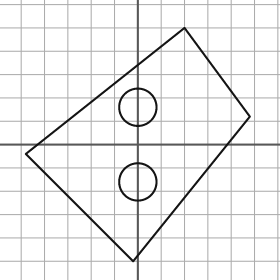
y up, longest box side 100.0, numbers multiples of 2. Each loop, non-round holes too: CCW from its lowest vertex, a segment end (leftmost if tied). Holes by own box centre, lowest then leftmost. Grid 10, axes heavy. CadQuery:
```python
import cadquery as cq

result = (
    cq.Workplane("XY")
    .moveTo(-2.0, -50.0)
    .lineTo(48.0, 12.0)
    .lineTo(20.0, 50.0)
    .lineTo(-48.0, -4.0)
    .close()
    .moveTo(0.0, -16.0)
    .circle(8.0)
    .moveTo(0.0, 16.0)
    .circle(8.0)
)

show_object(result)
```